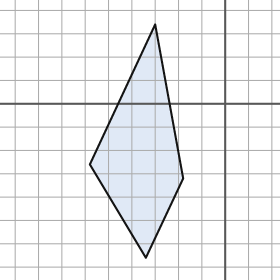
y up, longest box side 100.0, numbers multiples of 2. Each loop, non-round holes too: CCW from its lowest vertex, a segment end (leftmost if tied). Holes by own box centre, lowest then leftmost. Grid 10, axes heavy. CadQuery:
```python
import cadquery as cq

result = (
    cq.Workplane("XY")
    .moveTo(-34.0, -66.0)
    .lineTo(-18.0, -32.0)
    .lineTo(-30.0, 34.0)
    .lineTo(-58.0, -26.0)
    .close()
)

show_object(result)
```